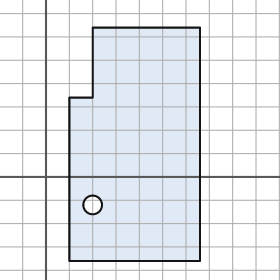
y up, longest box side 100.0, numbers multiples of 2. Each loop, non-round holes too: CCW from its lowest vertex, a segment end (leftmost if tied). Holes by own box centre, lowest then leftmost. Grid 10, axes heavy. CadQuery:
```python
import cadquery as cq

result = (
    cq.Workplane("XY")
    .moveTo(10.0, -36.0)
    .lineTo(66.0, -36.0)
    .lineTo(66.0, 64.0)
    .lineTo(20.0, 64.0)
    .lineTo(20.0, 34.0)
    .lineTo(10.0, 34.0)
    .close()
    .moveTo(20.0, -12.0)
    .circle(4.0)
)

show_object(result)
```